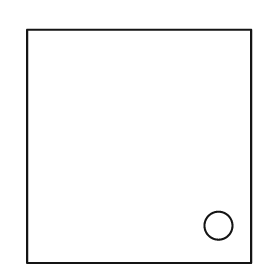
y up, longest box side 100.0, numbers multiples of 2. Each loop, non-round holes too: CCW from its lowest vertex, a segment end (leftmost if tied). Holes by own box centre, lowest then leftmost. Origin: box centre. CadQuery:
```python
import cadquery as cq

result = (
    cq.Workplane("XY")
    .moveTo(-48.0, -50.0)
    .lineTo(48.0, -50.0)
    .lineTo(48.0, 50.0)
    .lineTo(-48.0, 50.0)
    .close()
    .moveTo(34.0, -34.0)
    .circle(6.0)
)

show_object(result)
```